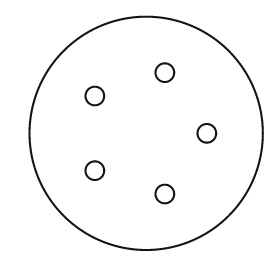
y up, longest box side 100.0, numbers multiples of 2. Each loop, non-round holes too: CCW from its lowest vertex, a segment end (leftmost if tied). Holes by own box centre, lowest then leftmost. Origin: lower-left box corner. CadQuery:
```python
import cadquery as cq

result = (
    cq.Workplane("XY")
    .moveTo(50.0, 50.0)
    .circle(50.0)
    .moveTo(58.0, 24.0)
    .circle(4.0)
    .moveTo(28.0, 34.0)
    .circle(4.0)
    .moveTo(76.0, 50.0)
    .circle(4.0)
    .moveTo(28.0, 66.0)
    .circle(4.0)
    .moveTo(58.0, 76.0)
    .circle(4.0)
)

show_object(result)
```